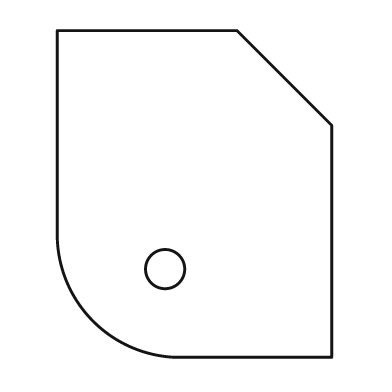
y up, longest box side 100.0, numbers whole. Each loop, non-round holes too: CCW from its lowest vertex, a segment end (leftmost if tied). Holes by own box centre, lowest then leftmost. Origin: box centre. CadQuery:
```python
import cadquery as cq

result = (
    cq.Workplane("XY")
    .moveTo(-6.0, -50.0)
    .lineTo(42.0, -50.0)
    .lineTo(42.0, 21.0)
    .lineTo(13.0, 50.0)
    .lineTo(-42.0, 50.0)
    .lineTo(-42.0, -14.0)
    .threePointArc((-31.0, -39.0), (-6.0, -50.0))
    .close()
    .moveTo(-9.0, -23.0)
    .circle(6.0)
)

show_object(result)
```